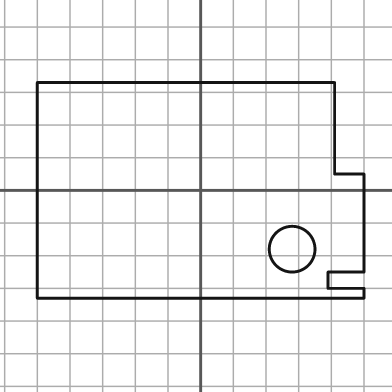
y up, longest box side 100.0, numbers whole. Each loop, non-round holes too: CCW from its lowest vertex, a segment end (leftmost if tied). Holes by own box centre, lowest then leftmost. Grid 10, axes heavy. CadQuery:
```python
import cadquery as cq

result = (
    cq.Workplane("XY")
    .moveTo(-50.0, -33.0)
    .lineTo(50.0, -33.0)
    .lineTo(50.0, -30.0)
    .lineTo(39.0, -30.0)
    .lineTo(39.0, -25.0)
    .lineTo(50.0, -25.0)
    .lineTo(50.0, 5.0)
    .lineTo(41.0, 5.0)
    .lineTo(41.0, 33.0)
    .lineTo(-50.0, 33.0)
    .close()
    .moveTo(28.0, -18.0)
    .circle(7.0)
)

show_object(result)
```